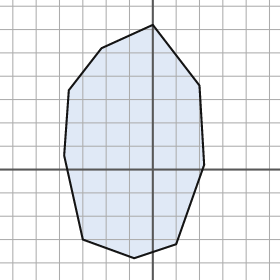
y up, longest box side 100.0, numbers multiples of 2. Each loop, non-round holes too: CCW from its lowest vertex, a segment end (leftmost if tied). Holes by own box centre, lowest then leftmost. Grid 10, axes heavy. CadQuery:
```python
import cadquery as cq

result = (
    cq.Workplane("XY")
    .moveTo(-8.0, -38.0)
    .lineTo(10.0, -32.0)
    .lineTo(22.0, 2.0)
    .lineTo(20.0, 36.0)
    .lineTo(0.0, 62.0)
    .lineTo(-22.0, 52.0)
    .lineTo(-36.0, 34.0)
    .lineTo(-38.0, 6.0)
    .lineTo(-30.0, -30.0)
    .close()
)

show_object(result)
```